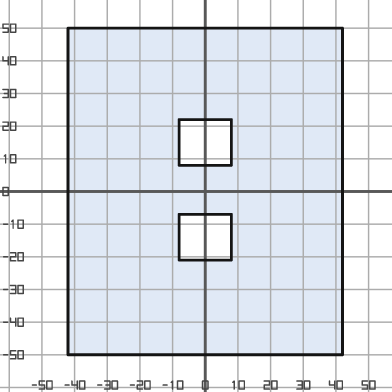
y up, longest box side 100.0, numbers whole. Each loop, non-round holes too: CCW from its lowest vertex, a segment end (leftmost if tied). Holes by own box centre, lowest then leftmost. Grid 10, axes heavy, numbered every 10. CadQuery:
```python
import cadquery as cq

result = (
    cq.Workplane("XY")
    .moveTo(-42.0, -50.0)
    .lineTo(42.0, -50.0)
    .lineTo(42.0, 50.0)
    .lineTo(-42.0, 50.0)
    .close()
    .moveTo(-8.0, -21.0)
    .lineTo(8.0, -21.0)
    .lineTo(8.0, -7.0)
    .lineTo(-8.0, -7.0)
    .close()
    .moveTo(-8.0, 8.0)
    .lineTo(8.0, 8.0)
    .lineTo(8.0, 22.0)
    .lineTo(-8.0, 22.0)
    .close()
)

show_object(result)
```